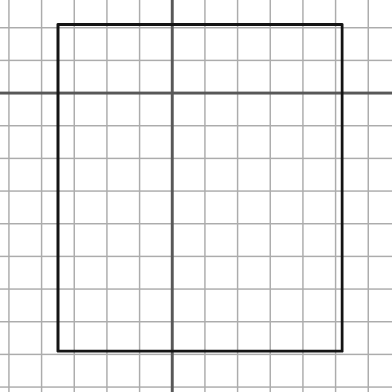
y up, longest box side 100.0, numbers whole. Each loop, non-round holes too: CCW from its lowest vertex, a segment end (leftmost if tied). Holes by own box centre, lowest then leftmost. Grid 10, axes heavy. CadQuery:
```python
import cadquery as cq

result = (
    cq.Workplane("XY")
    .moveTo(-35.0, -79.0)
    .lineTo(52.0, -79.0)
    .lineTo(52.0, 21.0)
    .lineTo(-35.0, 21.0)
    .close()
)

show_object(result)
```